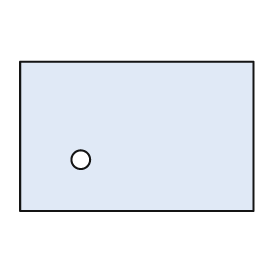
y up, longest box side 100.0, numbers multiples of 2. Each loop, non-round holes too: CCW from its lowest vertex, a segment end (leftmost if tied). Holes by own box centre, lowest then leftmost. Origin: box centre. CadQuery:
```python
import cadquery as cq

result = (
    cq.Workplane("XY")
    .moveTo(-50.0, -32.0)
    .lineTo(50.0, -32.0)
    .lineTo(50.0, 32.0)
    .lineTo(-50.0, 32.0)
    .close()
    .moveTo(-24.0, -10.0)
    .circle(4.0)
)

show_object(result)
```